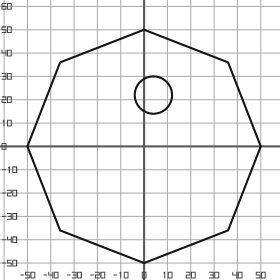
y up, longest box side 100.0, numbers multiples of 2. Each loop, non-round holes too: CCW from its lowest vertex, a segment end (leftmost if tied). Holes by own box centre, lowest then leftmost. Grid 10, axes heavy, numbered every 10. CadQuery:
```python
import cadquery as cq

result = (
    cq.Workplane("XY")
    .moveTo(0.0, -50.0)
    .lineTo(36.0, -36.0)
    .lineTo(50.0, 0.0)
    .lineTo(36.0, 36.0)
    .lineTo(0.0, 50.0)
    .lineTo(-36.0, 36.0)
    .lineTo(-50.0, 0.0)
    .lineTo(-36.0, -36.0)
    .close()
    .moveTo(4.0, 22.0)
    .circle(8.0)
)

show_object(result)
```